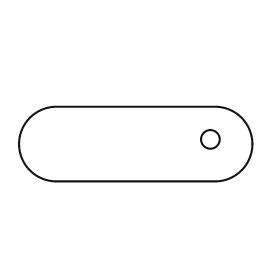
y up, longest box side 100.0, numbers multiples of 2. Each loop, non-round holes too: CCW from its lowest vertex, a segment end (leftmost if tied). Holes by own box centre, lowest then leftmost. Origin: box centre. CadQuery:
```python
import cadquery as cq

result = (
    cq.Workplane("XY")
    .moveTo(-34.0, -16.0)
    .lineTo(34.0, -16.0)
    .threePointArc((50.0, 0.0), (34.0, 16.0))
    .lineTo(-34.0, 16.0)
    .threePointArc((-50.0, 0.0), (-34.0, -16.0))
    .close()
    .moveTo(32.0, 2.0)
    .circle(4.0)
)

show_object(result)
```